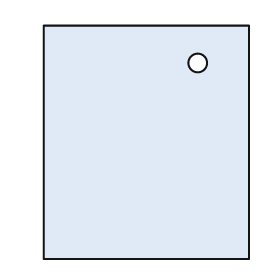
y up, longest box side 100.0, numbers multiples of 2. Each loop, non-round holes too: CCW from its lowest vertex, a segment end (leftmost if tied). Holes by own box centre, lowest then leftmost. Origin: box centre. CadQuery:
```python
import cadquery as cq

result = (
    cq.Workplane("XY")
    .moveTo(-44.0, -50.0)
    .lineTo(44.0, -50.0)
    .lineTo(44.0, 50.0)
    .lineTo(-44.0, 50.0)
    .close()
    .moveTo(22.0, 34.0)
    .circle(4.0)
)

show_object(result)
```